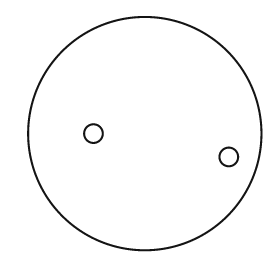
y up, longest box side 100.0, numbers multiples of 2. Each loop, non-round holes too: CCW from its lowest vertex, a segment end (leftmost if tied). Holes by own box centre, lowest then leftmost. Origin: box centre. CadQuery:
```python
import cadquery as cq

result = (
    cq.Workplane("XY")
    .moveTo(0.0, 0.0)
    .circle(50.0)
    .moveTo(36.0, -10.0)
    .circle(4.0)
    .moveTo(-22.0, 0.0)
    .circle(4.0)
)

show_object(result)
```